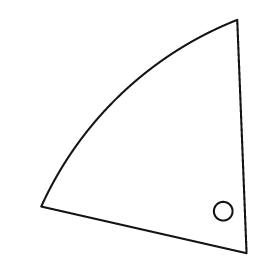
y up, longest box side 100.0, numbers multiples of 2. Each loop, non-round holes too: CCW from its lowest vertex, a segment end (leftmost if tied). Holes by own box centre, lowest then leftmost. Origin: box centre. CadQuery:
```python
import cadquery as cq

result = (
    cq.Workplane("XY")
    .moveTo(44.0, -50.0)
    .lineTo(40.0, 50.0)
    .threePointArc((-10.0, 18.0), (-44.0, -30.0))
    .close()
    .moveTo(34.0, -32.0)
    .circle(4.0)
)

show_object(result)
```